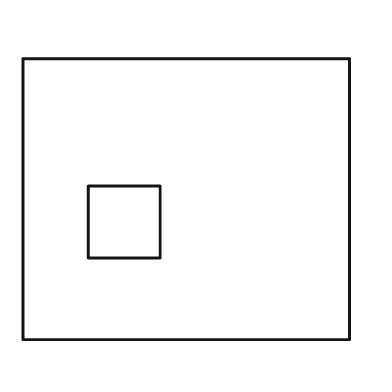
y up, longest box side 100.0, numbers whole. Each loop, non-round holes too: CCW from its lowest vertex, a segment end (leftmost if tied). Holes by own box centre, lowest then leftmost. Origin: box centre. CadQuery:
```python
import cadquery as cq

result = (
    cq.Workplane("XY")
    .moveTo(-50.0, -43.0)
    .lineTo(50.0, -43.0)
    .lineTo(50.0, 43.0)
    .lineTo(-50.0, 43.0)
    .close()
    .moveTo(-30.0, -18.0)
    .lineTo(-8.0, -18.0)
    .lineTo(-8.0, 4.0)
    .lineTo(-30.0, 4.0)
    .close()
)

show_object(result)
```